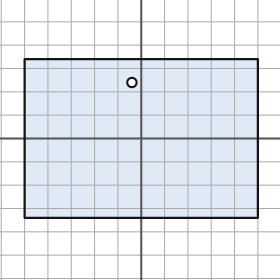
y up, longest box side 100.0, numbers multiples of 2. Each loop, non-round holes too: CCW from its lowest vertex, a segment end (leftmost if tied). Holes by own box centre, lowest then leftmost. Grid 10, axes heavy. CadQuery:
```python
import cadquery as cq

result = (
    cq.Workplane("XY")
    .moveTo(-50.0, -34.0)
    .lineTo(50.0, -34.0)
    .lineTo(50.0, 34.0)
    .lineTo(-50.0, 34.0)
    .close()
    .moveTo(-4.0, 24.0)
    .circle(2.0)
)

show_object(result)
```